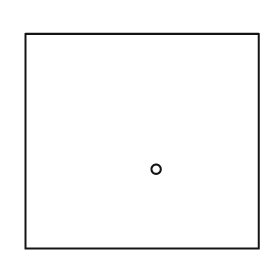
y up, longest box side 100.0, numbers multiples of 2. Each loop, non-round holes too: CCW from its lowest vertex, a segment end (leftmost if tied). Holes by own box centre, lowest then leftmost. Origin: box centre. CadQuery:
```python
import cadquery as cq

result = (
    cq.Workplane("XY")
    .moveTo(-50.0, -46.0)
    .lineTo(50.0, -46.0)
    .lineTo(50.0, 46.0)
    .lineTo(-50.0, 46.0)
    .close()
    .moveTo(6.0, -12.0)
    .circle(2.0)
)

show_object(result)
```